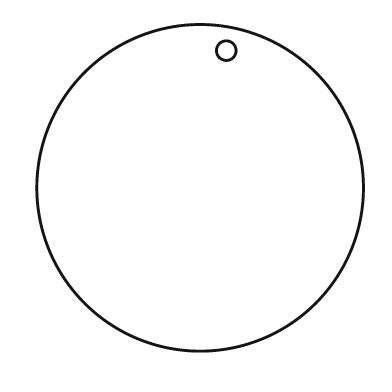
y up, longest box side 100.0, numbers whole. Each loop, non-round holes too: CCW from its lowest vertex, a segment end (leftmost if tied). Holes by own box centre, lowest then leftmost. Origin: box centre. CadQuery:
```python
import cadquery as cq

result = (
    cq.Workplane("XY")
    .moveTo(0.0, 0.0)
    .circle(50.0)
    .moveTo(8.0, 42.0)
    .circle(3.0)
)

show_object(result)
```